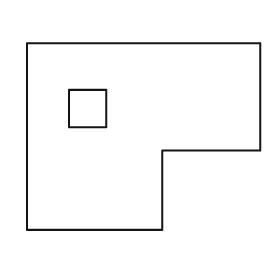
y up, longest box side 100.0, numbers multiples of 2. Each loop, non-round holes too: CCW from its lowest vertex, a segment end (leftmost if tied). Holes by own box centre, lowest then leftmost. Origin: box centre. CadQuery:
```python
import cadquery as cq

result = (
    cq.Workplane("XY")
    .moveTo(-50.0, -40.0)
    .lineTo(8.0, -40.0)
    .lineTo(8.0, -6.0)
    .lineTo(50.0, -6.0)
    .lineTo(50.0, 40.0)
    .lineTo(-50.0, 40.0)
    .close()
    .moveTo(-32.0, 4.0)
    .lineTo(-16.0, 4.0)
    .lineTo(-16.0, 20.0)
    .lineTo(-32.0, 20.0)
    .close()
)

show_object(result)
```